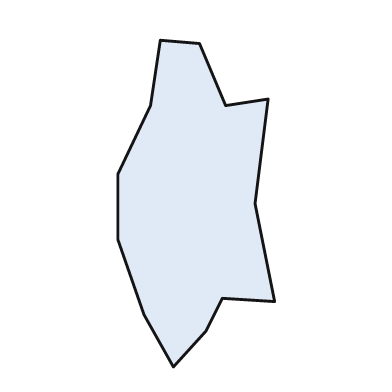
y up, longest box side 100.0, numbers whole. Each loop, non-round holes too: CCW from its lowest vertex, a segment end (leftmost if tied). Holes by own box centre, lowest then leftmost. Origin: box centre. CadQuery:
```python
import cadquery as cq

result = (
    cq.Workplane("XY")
    .moveTo(-7.0, -50.0)
    .lineTo(3.0, -39.0)
    .lineTo(8.0, -29.0)
    .lineTo(24.0, -30.0)
    .lineTo(18.0, 0.0)
    .lineTo(22.0, 32.0)
    .lineTo(9.0, 30.0)
    .lineTo(1.0, 49.0)
    .lineTo(-11.0, 50.0)
    .lineTo(-14.0, 30.0)
    .lineTo(-24.0, 9.0)
    .lineTo(-24.0, -11.0)
    .lineTo(-16.0, -34.0)
    .close()
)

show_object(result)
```